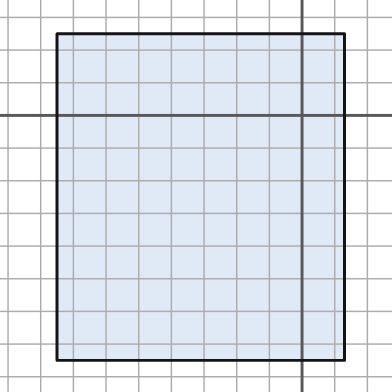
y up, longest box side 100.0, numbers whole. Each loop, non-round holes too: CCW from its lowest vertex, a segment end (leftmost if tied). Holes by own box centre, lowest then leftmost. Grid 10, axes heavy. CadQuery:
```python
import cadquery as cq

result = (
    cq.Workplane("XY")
    .moveTo(-75.0, -75.0)
    .lineTo(13.0, -75.0)
    .lineTo(13.0, 25.0)
    .lineTo(-75.0, 25.0)
    .close()
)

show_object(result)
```